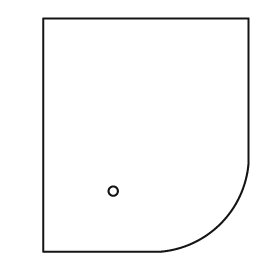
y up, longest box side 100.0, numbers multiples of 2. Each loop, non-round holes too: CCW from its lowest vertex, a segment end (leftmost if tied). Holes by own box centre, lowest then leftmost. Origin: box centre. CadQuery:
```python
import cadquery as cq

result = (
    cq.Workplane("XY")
    .moveTo(-44.0, -50.0)
    .lineTo(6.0, -50.0)
    .threePointArc((32.0, -38.0), (44.0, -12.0))
    .lineTo(44.0, 50.0)
    .lineTo(-44.0, 50.0)
    .close()
    .moveTo(-14.0, -24.0)
    .circle(2.0)
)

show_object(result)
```